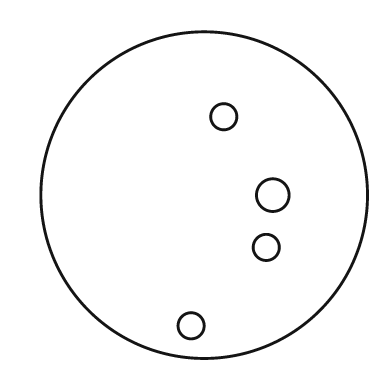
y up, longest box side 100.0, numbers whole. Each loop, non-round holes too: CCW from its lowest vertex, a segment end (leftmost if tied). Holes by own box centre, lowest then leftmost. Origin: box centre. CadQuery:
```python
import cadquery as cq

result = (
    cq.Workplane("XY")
    .moveTo(0.0, 0.0)
    .circle(50.0)
    .moveTo(-4.0, -40.0)
    .circle(4.0)
    .moveTo(19.0, -16.0)
    .circle(4.0)
    .moveTo(21.0, 0.0)
    .circle(5.0)
    .moveTo(6.0, 24.0)
    .circle(4.0)
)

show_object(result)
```